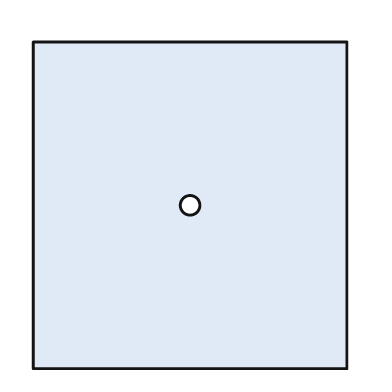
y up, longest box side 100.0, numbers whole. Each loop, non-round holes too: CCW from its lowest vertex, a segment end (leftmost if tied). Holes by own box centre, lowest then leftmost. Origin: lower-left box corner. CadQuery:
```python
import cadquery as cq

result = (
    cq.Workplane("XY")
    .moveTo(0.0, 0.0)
    .lineTo(96.0, 0.0)
    .lineTo(96.0, 100.0)
    .lineTo(0.0, 100.0)
    .close()
    .moveTo(48.0, 50.0)
    .circle(3.0)
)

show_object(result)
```